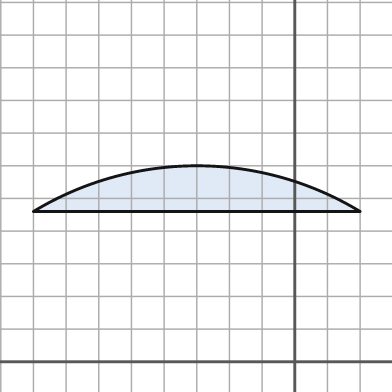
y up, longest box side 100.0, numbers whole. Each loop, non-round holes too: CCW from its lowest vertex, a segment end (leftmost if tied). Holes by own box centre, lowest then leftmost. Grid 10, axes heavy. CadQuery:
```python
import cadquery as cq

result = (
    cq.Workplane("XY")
    .moveTo(-80.0, 46.0)
    .lineTo(20.0, 46.0)
    .threePointArc((-30.0, 60.0), (-80.0, 46.0))
    .close()
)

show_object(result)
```